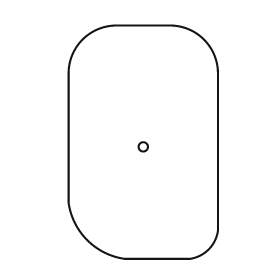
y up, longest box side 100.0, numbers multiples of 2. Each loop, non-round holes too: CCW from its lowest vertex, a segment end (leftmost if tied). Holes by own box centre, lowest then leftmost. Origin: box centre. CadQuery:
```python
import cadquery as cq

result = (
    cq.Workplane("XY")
    .moveTo(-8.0, -50.0)
    .lineTo(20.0, -50.0)
    .threePointArc((28.0, -46.0), (32.0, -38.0))
    .lineTo(32.0, 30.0)
    .threePointArc((26.0, 44.0), (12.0, 50.0))
    .lineTo(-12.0, 50.0)
    .threePointArc((-26.0, 44.0), (-32.0, 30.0))
    .lineTo(-32.0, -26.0)
    .threePointArc((-24.0, -42.0), (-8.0, -50.0))
    .close()
    .moveTo(0.0, -2.0)
    .circle(2.0)
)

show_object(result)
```